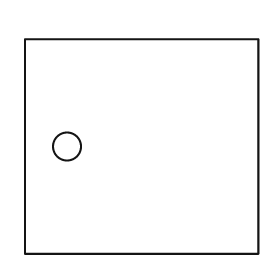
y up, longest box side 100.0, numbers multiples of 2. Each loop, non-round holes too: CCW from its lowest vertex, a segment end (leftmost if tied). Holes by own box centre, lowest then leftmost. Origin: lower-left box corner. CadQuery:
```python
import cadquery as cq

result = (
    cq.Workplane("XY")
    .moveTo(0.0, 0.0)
    .lineTo(100.0, 0.0)
    .lineTo(100.0, 92.0)
    .lineTo(0.0, 92.0)
    .close()
    .moveTo(18.0, 46.0)
    .circle(6.0)
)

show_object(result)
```